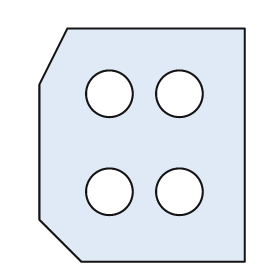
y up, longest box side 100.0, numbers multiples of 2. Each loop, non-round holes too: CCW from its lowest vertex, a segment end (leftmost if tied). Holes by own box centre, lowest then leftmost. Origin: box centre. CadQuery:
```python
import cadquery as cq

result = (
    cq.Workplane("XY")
    .moveTo(-26.0, -50.0)
    .lineTo(44.0, -50.0)
    .lineTo(44.0, 50.0)
    .lineTo(-32.0, 50.0)
    .lineTo(-44.0, 26.0)
    .lineTo(-44.0, -32.0)
    .close()
    .moveTo(-14.0, -20.0)
    .circle(10.0)
    .moveTo(16.0, -20.0)
    .circle(10.0)
    .moveTo(-14.0, 22.0)
    .circle(10.0)
    .moveTo(16.0, 22.0)
    .circle(10.0)
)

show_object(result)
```